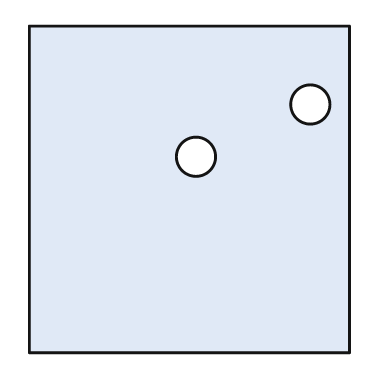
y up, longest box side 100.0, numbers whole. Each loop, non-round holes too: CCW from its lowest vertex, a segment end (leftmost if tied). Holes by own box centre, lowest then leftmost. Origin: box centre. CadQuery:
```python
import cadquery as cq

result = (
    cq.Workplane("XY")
    .moveTo(-49.0, -50.0)
    .lineTo(49.0, -50.0)
    .lineTo(49.0, 50.0)
    .lineTo(-49.0, 50.0)
    .close()
    .moveTo(2.0, 10.0)
    .circle(6.0)
    .moveTo(37.0, 26.0)
    .circle(6.0)
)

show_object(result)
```